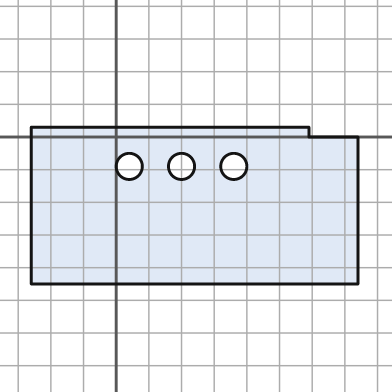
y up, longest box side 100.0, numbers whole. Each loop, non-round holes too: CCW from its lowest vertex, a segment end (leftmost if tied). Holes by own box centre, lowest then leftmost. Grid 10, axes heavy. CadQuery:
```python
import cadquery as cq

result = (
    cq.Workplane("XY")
    .moveTo(-26.0, -45.0)
    .lineTo(74.0, -45.0)
    .lineTo(74.0, 0.0)
    .lineTo(59.0, 0.0)
    .lineTo(59.0, 3.0)
    .lineTo(-26.0, 3.0)
    .close()
    .moveTo(4.0, -9.0)
    .circle(4.0)
    .moveTo(20.0, -9.0)
    .circle(4.0)
    .moveTo(36.0, -9.0)
    .circle(4.0)
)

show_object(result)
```